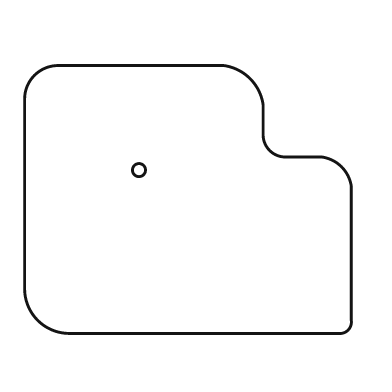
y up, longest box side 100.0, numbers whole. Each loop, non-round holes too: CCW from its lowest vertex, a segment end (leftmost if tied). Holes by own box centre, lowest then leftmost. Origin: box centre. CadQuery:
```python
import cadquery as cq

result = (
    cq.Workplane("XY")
    .moveTo(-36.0, -41.0)
    .lineTo(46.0, -41.0)
    .threePointArc((49.0, -40.0), (50.0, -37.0))
    .lineTo(50.0, 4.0)
    .threePointArc((47.0, 10.0), (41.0, 13.0))
    .lineTo(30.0, 13.0)
    .threePointArc((25.0, 15.0), (23.0, 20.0))
    .lineTo(23.0, 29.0)
    .threePointArc((19.0, 37.0), (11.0, 41.0))
    .lineTo(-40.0, 41.0)
    .threePointArc((-47.0, 38.0), (-50.0, 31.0))
    .lineTo(-50.0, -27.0)
    .threePointArc((-46.0, -37.0), (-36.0, -41.0))
    .close()
    .moveTo(-15.0, 9.0)
    .circle(2.0)
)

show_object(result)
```